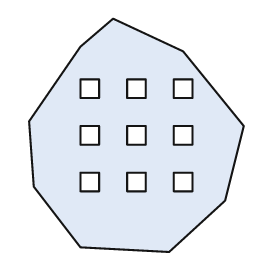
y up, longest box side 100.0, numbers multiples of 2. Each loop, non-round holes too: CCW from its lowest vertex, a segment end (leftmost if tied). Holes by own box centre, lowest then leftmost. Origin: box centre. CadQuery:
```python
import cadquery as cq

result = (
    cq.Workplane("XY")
    .moveTo(14.0, -50.0)
    .lineTo(38.0, -28.0)
    .lineTo(46.0, 4.0)
    .lineTo(20.0, 36.0)
    .lineTo(-10.0, 50.0)
    .lineTo(-24.0, 38.0)
    .lineTo(-46.0, 6.0)
    .lineTo(-44.0, -22.0)
    .lineTo(-24.0, -48.0)
    .close()
    .moveTo(-24.0, -24.0)
    .lineTo(-16.0, -24.0)
    .lineTo(-16.0, -16.0)
    .lineTo(-24.0, -16.0)
    .close()
    .moveTo(-4.0, -24.0)
    .lineTo(4.0, -24.0)
    .lineTo(4.0, -16.0)
    .lineTo(-4.0, -16.0)
    .close()
    .moveTo(16.0, -24.0)
    .lineTo(24.0, -24.0)
    .lineTo(24.0, -16.0)
    .lineTo(16.0, -16.0)
    .close()
    .moveTo(-24.0, -4.0)
    .lineTo(-16.0, -4.0)
    .lineTo(-16.0, 4.0)
    .lineTo(-24.0, 4.0)
    .close()
    .moveTo(-4.0, -4.0)
    .lineTo(4.0, -4.0)
    .lineTo(4.0, 4.0)
    .lineTo(-4.0, 4.0)
    .close()
    .moveTo(16.0, -4.0)
    .lineTo(24.0, -4.0)
    .lineTo(24.0, 4.0)
    .lineTo(16.0, 4.0)
    .close()
    .moveTo(-24.0, 16.0)
    .lineTo(-16.0, 16.0)
    .lineTo(-16.0, 24.0)
    .lineTo(-24.0, 24.0)
    .close()
    .moveTo(-4.0, 16.0)
    .lineTo(4.0, 16.0)
    .lineTo(4.0, 24.0)
    .lineTo(-4.0, 24.0)
    .close()
    .moveTo(16.0, 16.0)
    .lineTo(24.0, 16.0)
    .lineTo(24.0, 24.0)
    .lineTo(16.0, 24.0)
    .close()
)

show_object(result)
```